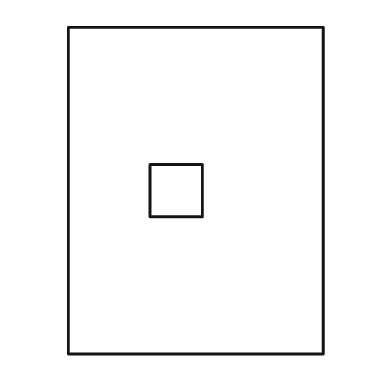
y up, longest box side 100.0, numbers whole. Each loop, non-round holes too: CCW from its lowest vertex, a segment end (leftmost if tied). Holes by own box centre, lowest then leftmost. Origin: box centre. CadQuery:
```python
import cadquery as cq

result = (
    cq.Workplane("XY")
    .moveTo(-39.0, -50.0)
    .lineTo(39.0, -50.0)
    .lineTo(39.0, 50.0)
    .lineTo(-39.0, 50.0)
    .close()
    .moveTo(-14.0, -8.0)
    .lineTo(2.0, -8.0)
    .lineTo(2.0, 8.0)
    .lineTo(-14.0, 8.0)
    .close()
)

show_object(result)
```